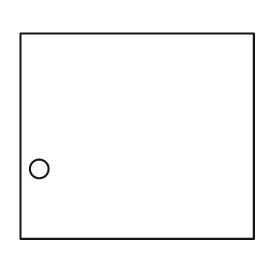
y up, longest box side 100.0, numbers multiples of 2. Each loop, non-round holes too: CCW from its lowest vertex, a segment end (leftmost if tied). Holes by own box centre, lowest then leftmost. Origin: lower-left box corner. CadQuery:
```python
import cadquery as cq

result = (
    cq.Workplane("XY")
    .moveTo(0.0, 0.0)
    .lineTo(100.0, 0.0)
    .lineTo(100.0, 88.0)
    .lineTo(0.0, 88.0)
    .close()
    .moveTo(8.0, 30.0)
    .circle(4.0)
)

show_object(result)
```